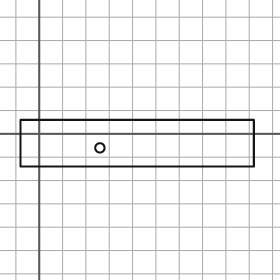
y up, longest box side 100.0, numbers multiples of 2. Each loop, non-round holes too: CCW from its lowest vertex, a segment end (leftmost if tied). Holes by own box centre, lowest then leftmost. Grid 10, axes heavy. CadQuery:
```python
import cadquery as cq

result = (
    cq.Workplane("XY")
    .moveTo(-8.0, -14.0)
    .lineTo(92.0, -14.0)
    .lineTo(92.0, 6.0)
    .lineTo(-8.0, 6.0)
    .close()
    .moveTo(26.0, -6.0)
    .circle(2.0)
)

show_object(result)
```